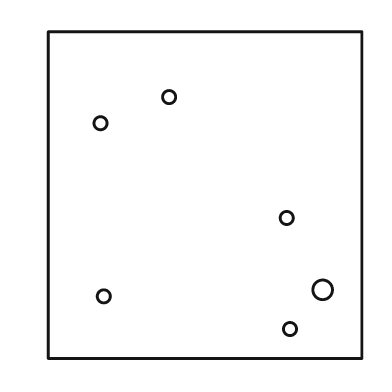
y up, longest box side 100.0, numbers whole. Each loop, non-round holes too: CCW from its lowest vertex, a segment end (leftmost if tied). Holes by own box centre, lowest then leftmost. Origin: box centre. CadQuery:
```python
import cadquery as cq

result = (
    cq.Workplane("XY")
    .moveTo(-48.0, -50.0)
    .lineTo(48.0, -50.0)
    .lineTo(48.0, 50.0)
    .lineTo(-48.0, 50.0)
    .close()
    .moveTo(26.0, -41.0)
    .circle(2.0)
    .moveTo(-31.0, -31.0)
    .circle(2.0)
    .moveTo(36.0, -29.0)
    .circle(3.0)
    .moveTo(25.0, -7.0)
    .circle(2.0)
    .moveTo(-32.0, 22.0)
    .circle(2.0)
    .moveTo(-11.0, 30.0)
    .circle(2.0)
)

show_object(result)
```